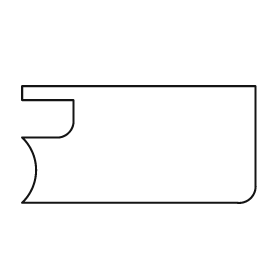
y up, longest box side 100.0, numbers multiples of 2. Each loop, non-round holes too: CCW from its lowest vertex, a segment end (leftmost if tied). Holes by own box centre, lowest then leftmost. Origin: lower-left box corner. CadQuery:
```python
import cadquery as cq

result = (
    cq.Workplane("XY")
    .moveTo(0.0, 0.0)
    .lineTo(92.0, 0.0)
    .threePointArc((98.0, 2.0), (100.0, 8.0))
    .lineTo(100.0, 50.0)
    .lineTo(0.0, 50.0)
    .lineTo(0.0, 44.0)
    .lineTo(22.0, 44.0)
    .lineTo(22.0, 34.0)
    .threePointArc((20.0, 30.0), (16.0, 28.0))
    .lineTo(0.0, 28.0)
    .threePointArc((6.0, 14.0), (0.0, 0.0))
    .close()
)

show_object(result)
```